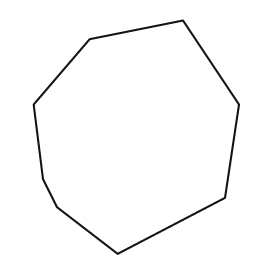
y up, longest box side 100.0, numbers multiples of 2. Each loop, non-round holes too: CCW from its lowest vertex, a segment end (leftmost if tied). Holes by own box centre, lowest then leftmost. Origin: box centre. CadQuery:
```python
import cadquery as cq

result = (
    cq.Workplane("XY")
    .moveTo(-8.0, -50.0)
    .lineTo(38.0, -26.0)
    .lineTo(44.0, 14.0)
    .lineTo(20.0, 50.0)
    .lineTo(-20.0, 42.0)
    .lineTo(-44.0, 14.0)
    .lineTo(-40.0, -18.0)
    .lineTo(-34.0, -30.0)
    .close()
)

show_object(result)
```